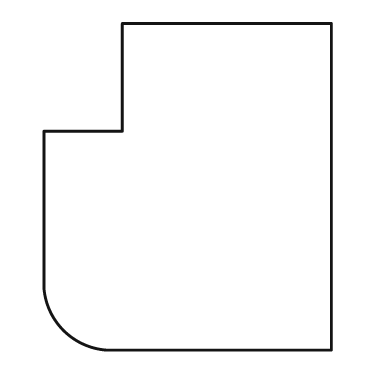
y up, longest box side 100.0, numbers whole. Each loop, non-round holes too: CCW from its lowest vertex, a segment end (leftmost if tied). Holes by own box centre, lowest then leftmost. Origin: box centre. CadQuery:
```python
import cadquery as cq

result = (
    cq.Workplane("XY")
    .moveTo(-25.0, -50.0)
    .lineTo(44.0, -50.0)
    .lineTo(44.0, 50.0)
    .lineTo(-20.0, 50.0)
    .lineTo(-20.0, 17.0)
    .lineTo(-44.0, 17.0)
    .lineTo(-44.0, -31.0)
    .threePointArc((-38.0, -44.0), (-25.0, -50.0))
    .close()
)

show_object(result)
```